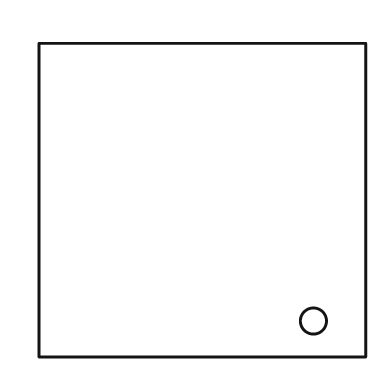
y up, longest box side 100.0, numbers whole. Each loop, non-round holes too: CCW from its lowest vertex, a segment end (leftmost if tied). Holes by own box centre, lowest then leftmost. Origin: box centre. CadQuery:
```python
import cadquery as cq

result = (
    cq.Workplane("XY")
    .moveTo(-50.0, -48.0)
    .lineTo(50.0, -48.0)
    .lineTo(50.0, 48.0)
    .lineTo(-50.0, 48.0)
    .close()
    .moveTo(34.0, -37.0)
    .circle(4.0)
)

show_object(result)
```